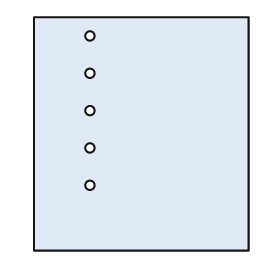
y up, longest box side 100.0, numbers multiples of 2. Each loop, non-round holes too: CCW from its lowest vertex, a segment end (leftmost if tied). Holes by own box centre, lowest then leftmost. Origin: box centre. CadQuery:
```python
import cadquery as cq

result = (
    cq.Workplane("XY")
    .moveTo(-46.0, -50.0)
    .lineTo(46.0, -50.0)
    .lineTo(46.0, 50.0)
    .lineTo(-46.0, 50.0)
    .close()
    .moveTo(-22.0, -22.0)
    .circle(2.0)
    .moveTo(-22.0, -6.0)
    .circle(2.0)
    .moveTo(-22.0, 10.0)
    .circle(2.0)
    .moveTo(-22.0, 26.0)
    .circle(2.0)
    .moveTo(-22.0, 42.0)
    .circle(2.0)
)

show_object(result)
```